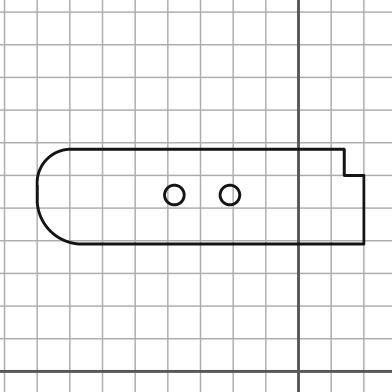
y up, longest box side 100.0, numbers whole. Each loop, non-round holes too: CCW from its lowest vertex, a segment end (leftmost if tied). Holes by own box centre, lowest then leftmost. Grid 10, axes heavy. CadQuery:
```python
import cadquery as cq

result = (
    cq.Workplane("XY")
    .moveTo(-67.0, 39.0)
    .lineTo(20.0, 39.0)
    .lineTo(20.0, 60.0)
    .lineTo(14.0, 60.0)
    .lineTo(14.0, 68.0)
    .lineTo(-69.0, 68.0)
    .threePointArc((-77.0, 65.0), (-80.0, 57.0))
    .lineTo(-80.0, 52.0)
    .threePointArc((-76.0, 43.0), (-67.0, 39.0))
    .close()
    .moveTo(-38.0, 54.0)
    .circle(3.0)
    .moveTo(-21.0, 54.0)
    .circle(3.0)
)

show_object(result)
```